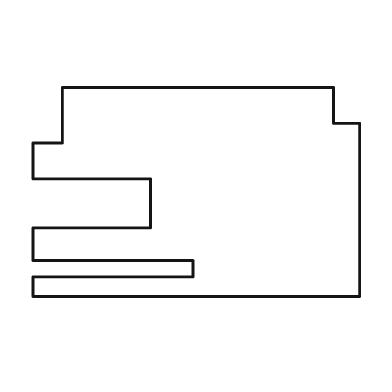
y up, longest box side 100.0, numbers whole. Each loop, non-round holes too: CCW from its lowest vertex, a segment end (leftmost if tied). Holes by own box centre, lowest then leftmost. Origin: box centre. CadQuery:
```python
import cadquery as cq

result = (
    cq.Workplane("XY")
    .moveTo(-50.0, -32.0)
    .lineTo(50.0, -32.0)
    .lineTo(50.0, 21.0)
    .lineTo(42.0, 21.0)
    .lineTo(42.0, 32.0)
    .lineTo(-41.0, 32.0)
    .lineTo(-41.0, 15.0)
    .lineTo(-50.0, 15.0)
    .lineTo(-50.0, 4.0)
    .lineTo(-14.0, 4.0)
    .lineTo(-14.0, -11.0)
    .lineTo(-50.0, -11.0)
    .lineTo(-50.0, -21.0)
    .lineTo(-1.0, -21.0)
    .lineTo(-1.0, -26.0)
    .lineTo(-50.0, -26.0)
    .close()
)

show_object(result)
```